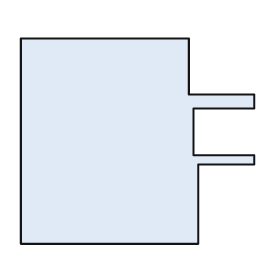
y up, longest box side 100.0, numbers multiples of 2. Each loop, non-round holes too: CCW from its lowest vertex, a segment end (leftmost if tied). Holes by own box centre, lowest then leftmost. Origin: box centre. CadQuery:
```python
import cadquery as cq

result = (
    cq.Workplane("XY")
    .moveTo(-50.0, -44.0)
    .lineTo(26.0, -44.0)
    .lineTo(26.0, -10.0)
    .lineTo(50.0, -10.0)
    .lineTo(50.0, -6.0)
    .lineTo(24.0, -6.0)
    .lineTo(24.0, 14.0)
    .lineTo(50.0, 14.0)
    .lineTo(50.0, 20.0)
    .lineTo(22.0, 20.0)
    .lineTo(22.0, 44.0)
    .lineTo(-50.0, 44.0)
    .close()
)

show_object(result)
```